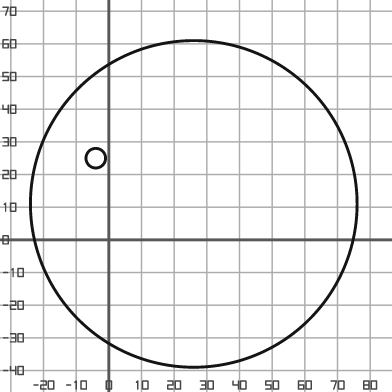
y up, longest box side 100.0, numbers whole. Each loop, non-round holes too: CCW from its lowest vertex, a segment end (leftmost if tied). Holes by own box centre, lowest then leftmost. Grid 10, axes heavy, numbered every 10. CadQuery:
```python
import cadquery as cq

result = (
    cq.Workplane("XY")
    .moveTo(26.0, 11.0)
    .circle(50.0)
    .moveTo(-4.0, 25.0)
    .circle(3.0)
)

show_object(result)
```